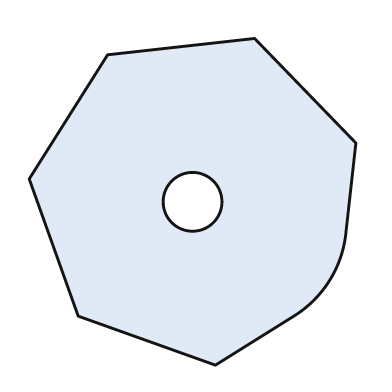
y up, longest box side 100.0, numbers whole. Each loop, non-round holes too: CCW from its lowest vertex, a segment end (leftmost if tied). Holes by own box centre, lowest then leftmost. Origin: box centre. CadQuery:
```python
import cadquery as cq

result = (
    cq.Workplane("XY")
    .moveTo(7.0, -50.0)
    .lineTo(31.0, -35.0)
    .threePointArc((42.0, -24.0), (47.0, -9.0))
    .lineTo(50.0, 18.0)
    .lineTo(19.0, 50.0)
    .lineTo(-26.0, 45.0)
    .lineTo(-50.0, 7.0)
    .lineTo(-35.0, -35.0)
    .close()
    .moveTo(0.0, 0.0)
    .circle(9.0)
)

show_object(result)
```